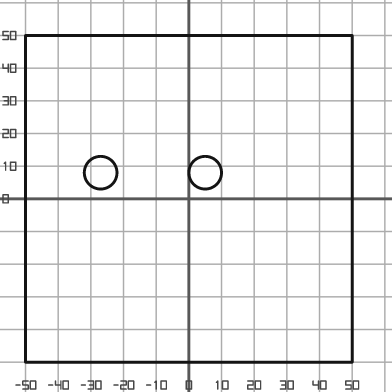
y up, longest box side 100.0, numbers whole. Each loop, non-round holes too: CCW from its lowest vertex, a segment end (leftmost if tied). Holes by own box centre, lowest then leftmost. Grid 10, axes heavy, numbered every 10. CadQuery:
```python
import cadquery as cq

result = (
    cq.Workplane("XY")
    .moveTo(-50.0, -50.0)
    .lineTo(50.0, -50.0)
    .lineTo(50.0, 50.0)
    .lineTo(-50.0, 50.0)
    .close()
    .moveTo(-27.0, 8.0)
    .circle(5.0)
    .moveTo(5.0, 8.0)
    .circle(5.0)
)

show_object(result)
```